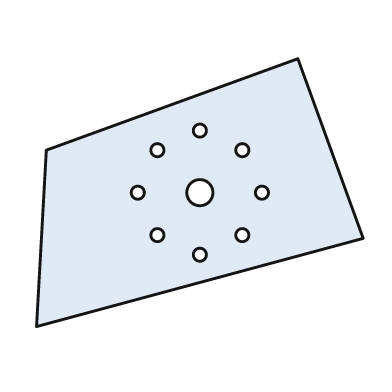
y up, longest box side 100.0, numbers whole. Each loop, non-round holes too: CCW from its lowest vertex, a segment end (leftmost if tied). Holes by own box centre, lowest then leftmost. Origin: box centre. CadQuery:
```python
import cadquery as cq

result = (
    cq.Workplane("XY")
    .moveTo(-50.0, -41.0)
    .lineTo(50.0, -14.0)
    .lineTo(30.0, 41.0)
    .lineTo(-47.0, 13.0)
    .close()
    .moveTo(0.0, -19.0)
    .circle(2.0)
    .moveTo(-13.0, -13.0)
    .circle(2.0)
    .moveTo(13.0, -13.0)
    .circle(2.0)
    .moveTo(-19.0, 0.0)
    .circle(2.0)
    .moveTo(0.0, 0.0)
    .circle(4.0)
    .moveTo(19.0, 0.0)
    .circle(2.0)
    .moveTo(-13.0, 13.0)
    .circle(2.0)
    .moveTo(13.0, 13.0)
    .circle(2.0)
    .moveTo(0.0, 19.0)
    .circle(2.0)
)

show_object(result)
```